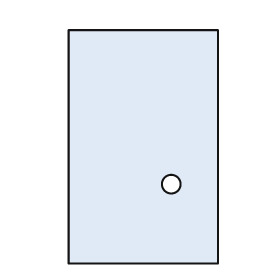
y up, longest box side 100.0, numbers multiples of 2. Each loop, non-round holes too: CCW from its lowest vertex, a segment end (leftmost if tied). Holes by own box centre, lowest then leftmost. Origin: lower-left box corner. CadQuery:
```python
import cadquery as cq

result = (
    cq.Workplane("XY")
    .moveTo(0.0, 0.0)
    .lineTo(64.0, 0.0)
    .lineTo(64.0, 100.0)
    .lineTo(0.0, 100.0)
    .close()
    .moveTo(44.0, 34.0)
    .circle(4.0)
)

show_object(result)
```